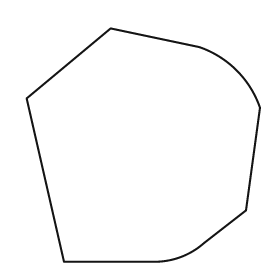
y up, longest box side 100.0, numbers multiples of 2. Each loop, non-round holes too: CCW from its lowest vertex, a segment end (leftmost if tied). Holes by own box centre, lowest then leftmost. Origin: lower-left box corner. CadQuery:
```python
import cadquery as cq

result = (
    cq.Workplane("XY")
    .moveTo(16.0, 0.0)
    .lineTo(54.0, 0.0)
    .threePointArc((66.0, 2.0), (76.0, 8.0))
    .lineTo(94.0, 22.0)
    .lineTo(100.0, 66.0)
    .threePointArc((90.0, 82.0), (74.0, 92.0))
    .lineTo(36.0, 100.0)
    .lineTo(0.0, 70.0)
    .close()
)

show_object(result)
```